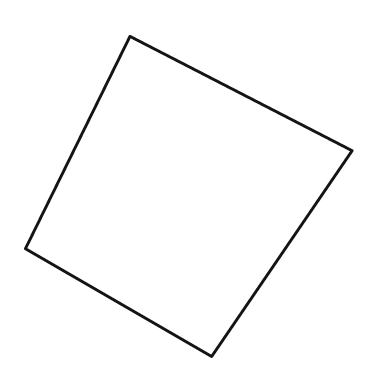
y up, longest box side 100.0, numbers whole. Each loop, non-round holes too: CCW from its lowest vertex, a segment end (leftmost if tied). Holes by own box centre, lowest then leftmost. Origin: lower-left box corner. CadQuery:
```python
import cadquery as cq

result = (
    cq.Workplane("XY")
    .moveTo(57.0, 0.0)
    .lineTo(100.0, 63.0)
    .lineTo(32.0, 98.0)
    .lineTo(0.0, 33.0)
    .close()
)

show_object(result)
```